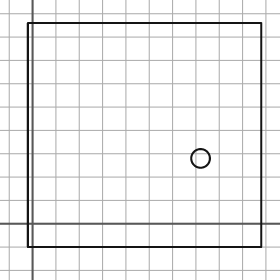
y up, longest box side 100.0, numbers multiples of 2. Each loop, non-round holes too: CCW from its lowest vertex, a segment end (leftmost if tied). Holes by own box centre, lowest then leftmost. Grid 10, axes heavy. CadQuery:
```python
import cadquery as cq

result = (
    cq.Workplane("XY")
    .moveTo(-2.0, -10.0)
    .lineTo(98.0, -10.0)
    .lineTo(98.0, 86.0)
    .lineTo(-2.0, 86.0)
    .close()
    .moveTo(72.0, 28.0)
    .circle(4.0)
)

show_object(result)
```